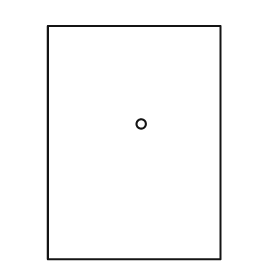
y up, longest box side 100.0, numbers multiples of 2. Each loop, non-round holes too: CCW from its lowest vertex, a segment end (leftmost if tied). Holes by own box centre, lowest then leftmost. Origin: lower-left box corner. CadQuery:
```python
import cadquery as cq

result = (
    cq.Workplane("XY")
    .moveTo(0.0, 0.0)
    .lineTo(74.0, 0.0)
    .lineTo(74.0, 100.0)
    .lineTo(0.0, 100.0)
    .close()
    .moveTo(40.0, 58.0)
    .circle(2.0)
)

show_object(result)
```